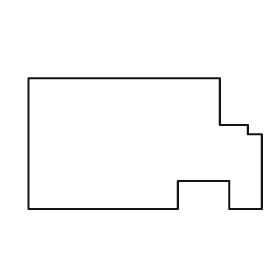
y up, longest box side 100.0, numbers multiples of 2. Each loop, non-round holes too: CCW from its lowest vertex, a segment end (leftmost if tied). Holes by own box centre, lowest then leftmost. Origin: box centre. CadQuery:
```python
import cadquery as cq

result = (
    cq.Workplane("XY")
    .moveTo(-50.0, -28.0)
    .lineTo(14.0, -28.0)
    .lineTo(14.0, -16.0)
    .lineTo(36.0, -16.0)
    .lineTo(36.0, -28.0)
    .lineTo(50.0, -28.0)
    .lineTo(50.0, 4.0)
    .lineTo(44.0, 4.0)
    .lineTo(44.0, 8.0)
    .lineTo(32.0, 8.0)
    .lineTo(32.0, 28.0)
    .lineTo(-50.0, 28.0)
    .close()
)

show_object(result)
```